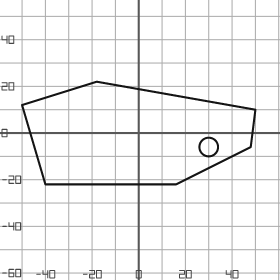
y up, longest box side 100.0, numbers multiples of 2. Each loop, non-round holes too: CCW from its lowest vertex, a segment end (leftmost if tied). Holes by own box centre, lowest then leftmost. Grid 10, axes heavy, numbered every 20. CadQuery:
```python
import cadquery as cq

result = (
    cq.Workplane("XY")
    .moveTo(-40.0, -22.0)
    .lineTo(16.0, -22.0)
    .lineTo(48.0, -6.0)
    .lineTo(50.0, 10.0)
    .lineTo(-18.0, 22.0)
    .lineTo(-50.0, 12.0)
    .close()
    .moveTo(30.0, -6.0)
    .circle(4.0)
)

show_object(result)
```